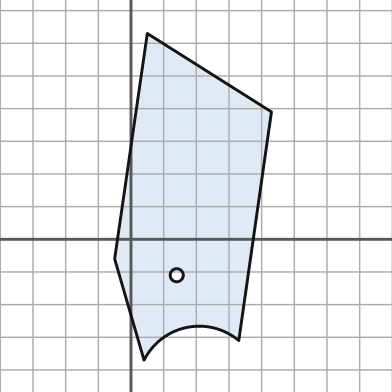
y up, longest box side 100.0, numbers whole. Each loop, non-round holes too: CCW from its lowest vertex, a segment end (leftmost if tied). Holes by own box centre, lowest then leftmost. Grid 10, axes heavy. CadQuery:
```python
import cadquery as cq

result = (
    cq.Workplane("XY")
    .moveTo(4.0, -37.0)
    .threePointArc((17.0, -27.0), (33.0, -31.0))
    .lineTo(43.0, 39.0)
    .lineTo(5.0, 63.0)
    .lineTo(-5.0, -6.0)
    .close()
    .moveTo(14.0, -11.0)
    .circle(2.0)
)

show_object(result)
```